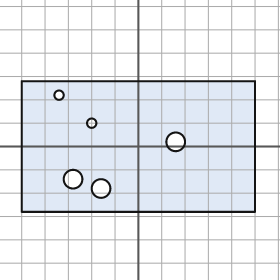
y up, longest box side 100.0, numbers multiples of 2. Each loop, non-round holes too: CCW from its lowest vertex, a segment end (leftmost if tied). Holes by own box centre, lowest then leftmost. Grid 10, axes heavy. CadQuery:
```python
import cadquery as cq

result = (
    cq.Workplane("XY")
    .moveTo(-50.0, -28.0)
    .lineTo(50.0, -28.0)
    .lineTo(50.0, 28.0)
    .lineTo(-50.0, 28.0)
    .close()
    .moveTo(-16.0, -18.0)
    .circle(4.0)
    .moveTo(-28.0, -14.0)
    .circle(4.0)
    .moveTo(16.0, 2.0)
    .circle(4.0)
    .moveTo(-20.0, 10.0)
    .circle(2.0)
    .moveTo(-34.0, 22.0)
    .circle(2.0)
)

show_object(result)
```